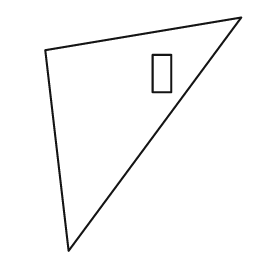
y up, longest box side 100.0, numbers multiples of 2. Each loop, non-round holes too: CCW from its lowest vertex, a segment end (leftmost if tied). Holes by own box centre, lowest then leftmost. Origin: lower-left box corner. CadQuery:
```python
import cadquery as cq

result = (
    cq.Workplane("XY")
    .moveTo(10.0, 0.0)
    .lineTo(84.0, 100.0)
    .lineTo(0.0, 86.0)
    .close()
    .moveTo(46.0, 68.0)
    .lineTo(54.0, 68.0)
    .lineTo(54.0, 84.0)
    .lineTo(46.0, 84.0)
    .close()
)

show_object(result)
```